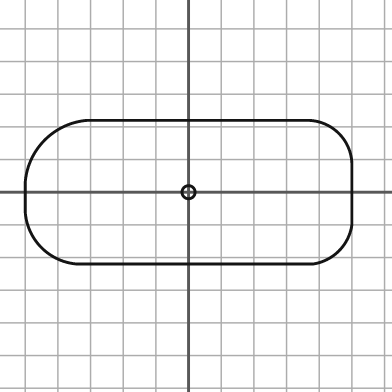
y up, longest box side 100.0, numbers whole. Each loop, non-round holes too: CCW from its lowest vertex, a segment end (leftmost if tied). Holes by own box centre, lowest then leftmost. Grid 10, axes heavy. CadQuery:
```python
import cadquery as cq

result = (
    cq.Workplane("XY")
    .moveTo(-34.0, -22.0)
    .lineTo(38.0, -22.0)
    .threePointArc((46.0, -18.0), (50.0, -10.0))
    .lineTo(50.0, 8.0)
    .threePointArc((46.0, 18.0), (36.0, 22.0))
    .lineTo(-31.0, 22.0)
    .threePointArc((-44.0, 16.0), (-50.0, 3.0))
    .lineTo(-50.0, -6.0)
    .threePointArc((-45.0, -17.0), (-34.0, -22.0))
    .close()
    .moveTo(0.0, 0.0)
    .circle(2.0)
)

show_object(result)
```